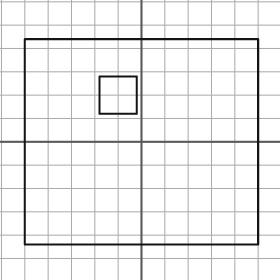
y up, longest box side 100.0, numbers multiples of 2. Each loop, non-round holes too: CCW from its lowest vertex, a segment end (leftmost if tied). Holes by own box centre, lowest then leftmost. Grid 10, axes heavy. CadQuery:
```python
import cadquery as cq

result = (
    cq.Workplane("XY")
    .moveTo(-50.0, -44.0)
    .lineTo(50.0, -44.0)
    .lineTo(50.0, 44.0)
    .lineTo(-50.0, 44.0)
    .close()
    .moveTo(-18.0, 12.0)
    .lineTo(-2.0, 12.0)
    .lineTo(-2.0, 28.0)
    .lineTo(-18.0, 28.0)
    .close()
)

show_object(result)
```